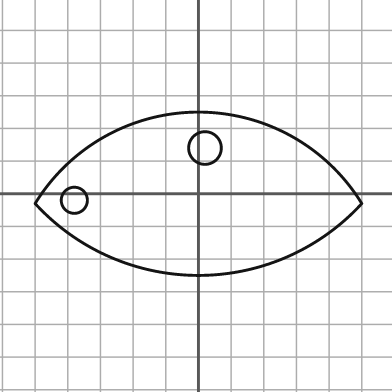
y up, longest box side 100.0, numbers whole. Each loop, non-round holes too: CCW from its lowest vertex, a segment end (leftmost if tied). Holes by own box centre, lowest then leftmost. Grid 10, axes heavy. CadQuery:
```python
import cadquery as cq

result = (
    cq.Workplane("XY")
    .moveTo(-50.0, -3.0)
    .threePointArc((0.0, -25.0), (50.0, -3.0))
    .threePointArc((0.0, 25.0), (-50.0, -3.0))
    .close()
    .moveTo(-38.0, -2.0)
    .circle(4.0)
    .moveTo(2.0, 14.0)
    .circle(5.0)
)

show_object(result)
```